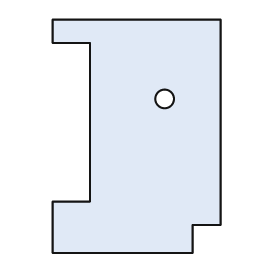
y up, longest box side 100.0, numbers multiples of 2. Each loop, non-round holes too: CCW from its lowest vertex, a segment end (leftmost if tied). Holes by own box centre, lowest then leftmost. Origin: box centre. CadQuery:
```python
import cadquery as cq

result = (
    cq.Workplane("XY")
    .moveTo(-36.0, -50.0)
    .lineTo(24.0, -50.0)
    .lineTo(24.0, -38.0)
    .lineTo(36.0, -38.0)
    .lineTo(36.0, 50.0)
    .lineTo(-36.0, 50.0)
    .lineTo(-36.0, 40.0)
    .lineTo(-20.0, 40.0)
    .lineTo(-20.0, -28.0)
    .lineTo(-36.0, -28.0)
    .close()
    .moveTo(12.0, 16.0)
    .circle(4.0)
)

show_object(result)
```